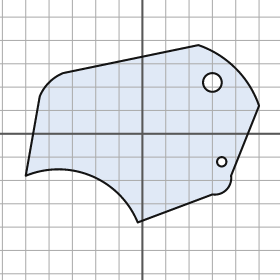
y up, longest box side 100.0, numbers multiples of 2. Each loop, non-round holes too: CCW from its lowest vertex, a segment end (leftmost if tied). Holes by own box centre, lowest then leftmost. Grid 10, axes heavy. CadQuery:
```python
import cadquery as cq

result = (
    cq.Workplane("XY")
    .moveTo(-2.0, -38.0)
    .lineTo(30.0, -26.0)
    .threePointArc((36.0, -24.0), (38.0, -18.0))
    .lineTo(50.0, 12.0)
    .threePointArc((40.0, 28.0), (24.0, 38.0))
    .lineTo(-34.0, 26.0)
    .threePointArc((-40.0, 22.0), (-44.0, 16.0))
    .lineTo(-50.0, -18.0)
    .threePointArc((-22.0, -18.0), (-2.0, -38.0))
    .close()
    .moveTo(34.0, -12.0)
    .circle(2.0)
    .moveTo(30.0, 22.0)
    .circle(4.0)
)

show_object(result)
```